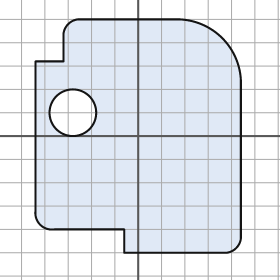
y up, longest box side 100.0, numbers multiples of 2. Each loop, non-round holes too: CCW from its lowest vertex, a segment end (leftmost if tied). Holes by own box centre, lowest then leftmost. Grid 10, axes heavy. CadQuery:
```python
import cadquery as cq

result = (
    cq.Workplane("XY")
    .moveTo(-6.0, -50.0)
    .lineTo(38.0, -50.0)
    .threePointArc((42.0, -48.0), (44.0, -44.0))
    .lineTo(44.0, 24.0)
    .threePointArc((36.0, 42.0), (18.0, 50.0))
    .lineTo(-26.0, 50.0)
    .threePointArc((-30.0, 48.0), (-32.0, 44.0))
    .lineTo(-32.0, 32.0)
    .lineTo(-44.0, 32.0)
    .lineTo(-44.0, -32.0)
    .threePointArc((-42.0, -38.0), (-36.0, -40.0))
    .lineTo(-6.0, -40.0)
    .close()
    .moveTo(-28.0, 10.0)
    .circle(10.0)
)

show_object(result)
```